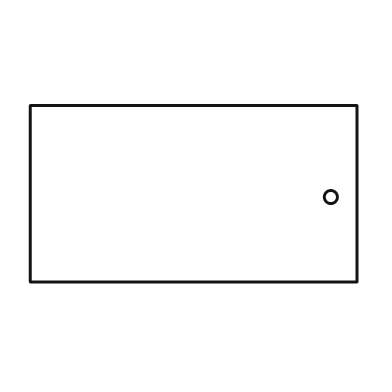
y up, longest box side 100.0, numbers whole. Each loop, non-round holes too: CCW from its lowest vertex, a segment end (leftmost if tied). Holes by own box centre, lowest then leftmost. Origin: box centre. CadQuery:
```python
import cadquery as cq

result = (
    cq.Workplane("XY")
    .moveTo(-50.0, -27.0)
    .lineTo(50.0, -27.0)
    .lineTo(50.0, 27.0)
    .lineTo(-50.0, 27.0)
    .close()
    .moveTo(42.0, -1.0)
    .circle(2.0)
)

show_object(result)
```